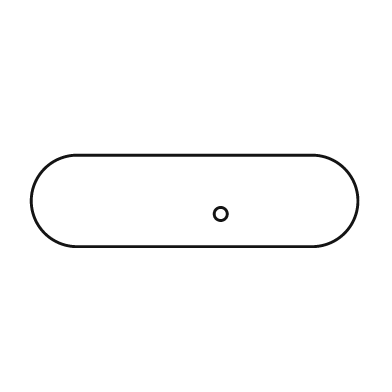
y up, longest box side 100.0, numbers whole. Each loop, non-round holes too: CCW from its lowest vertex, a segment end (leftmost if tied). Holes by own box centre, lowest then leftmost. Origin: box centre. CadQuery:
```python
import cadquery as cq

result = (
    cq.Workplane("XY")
    .moveTo(-36.0, -14.0)
    .lineTo(36.0, -14.0)
    .threePointArc((50.0, 0.0), (36.0, 14.0))
    .lineTo(-36.0, 14.0)
    .threePointArc((-50.0, 0.0), (-36.0, -14.0))
    .close()
    .moveTo(8.0, -4.0)
    .circle(2.0)
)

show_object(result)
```